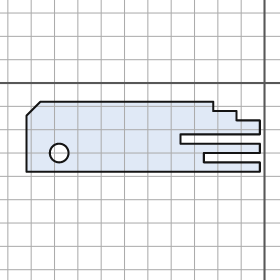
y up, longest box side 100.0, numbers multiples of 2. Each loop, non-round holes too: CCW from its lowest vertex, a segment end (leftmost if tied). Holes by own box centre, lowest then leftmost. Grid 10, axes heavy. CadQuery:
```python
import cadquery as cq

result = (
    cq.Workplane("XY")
    .moveTo(-102.0, -38.0)
    .lineTo(-2.0, -38.0)
    .lineTo(-2.0, -34.0)
    .lineTo(-26.0, -34.0)
    .lineTo(-26.0, -30.0)
    .lineTo(-2.0, -30.0)
    .lineTo(-2.0, -26.0)
    .lineTo(-36.0, -26.0)
    .lineTo(-36.0, -22.0)
    .lineTo(-2.0, -22.0)
    .lineTo(-2.0, -16.0)
    .lineTo(-12.0, -16.0)
    .lineTo(-12.0, -12.0)
    .lineTo(-22.0, -12.0)
    .lineTo(-22.0, -8.0)
    .lineTo(-96.0, -8.0)
    .lineTo(-102.0, -14.0)
    .close()
    .moveTo(-88.0, -30.0)
    .circle(4.0)
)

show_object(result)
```